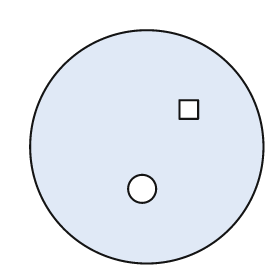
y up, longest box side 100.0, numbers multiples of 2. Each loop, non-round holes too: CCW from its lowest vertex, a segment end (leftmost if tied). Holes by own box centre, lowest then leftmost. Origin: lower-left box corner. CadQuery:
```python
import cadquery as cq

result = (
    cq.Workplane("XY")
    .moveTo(50.0, 50.0)
    .circle(50.0)
    .moveTo(48.0, 32.0)
    .circle(6.0)
    .moveTo(64.0, 62.0)
    .lineTo(72.0, 62.0)
    .lineTo(72.0, 70.0)
    .lineTo(64.0, 70.0)
    .close()
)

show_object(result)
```